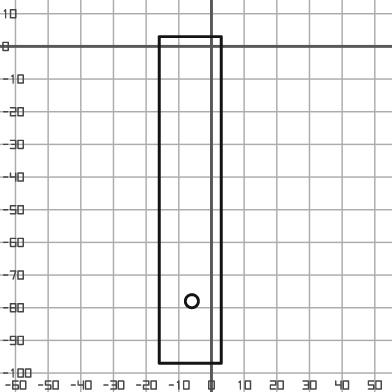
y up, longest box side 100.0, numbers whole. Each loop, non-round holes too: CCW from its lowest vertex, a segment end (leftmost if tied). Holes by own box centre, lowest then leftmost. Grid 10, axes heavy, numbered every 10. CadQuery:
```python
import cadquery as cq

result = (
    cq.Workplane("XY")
    .moveTo(-16.0, -97.0)
    .lineTo(3.0, -97.0)
    .lineTo(3.0, 3.0)
    .lineTo(-16.0, 3.0)
    .close()
    .moveTo(-6.0, -78.0)
    .circle(2.0)
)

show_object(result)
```